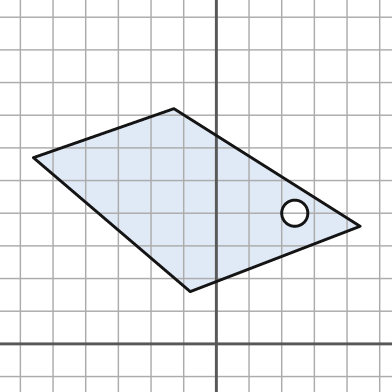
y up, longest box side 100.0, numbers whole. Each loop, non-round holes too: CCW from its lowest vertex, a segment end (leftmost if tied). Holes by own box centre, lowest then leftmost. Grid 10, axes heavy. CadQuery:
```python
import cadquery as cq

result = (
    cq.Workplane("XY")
    .moveTo(-8.0, 16.0)
    .lineTo(44.0, 36.0)
    .lineTo(-13.0, 72.0)
    .lineTo(-56.0, 57.0)
    .close()
    .moveTo(24.0, 40.0)
    .circle(4.0)
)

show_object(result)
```